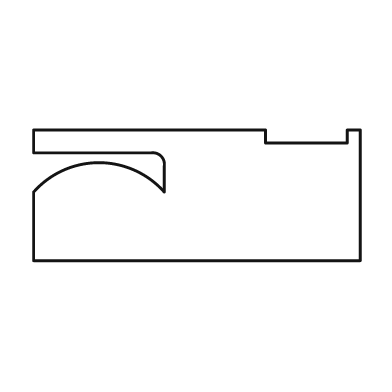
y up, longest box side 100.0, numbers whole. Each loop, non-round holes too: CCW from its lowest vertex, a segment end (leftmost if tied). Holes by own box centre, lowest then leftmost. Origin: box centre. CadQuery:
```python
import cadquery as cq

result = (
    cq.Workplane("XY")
    .moveTo(-50.0, -20.0)
    .lineTo(50.0, -20.0)
    .lineTo(50.0, 20.0)
    .lineTo(46.0, 20.0)
    .lineTo(46.0, 16.0)
    .lineTo(21.0, 16.0)
    .lineTo(21.0, 20.0)
    .lineTo(-50.0, 20.0)
    .lineTo(-50.0, 13.0)
    .lineTo(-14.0, 13.0)
    .threePointArc((-11.0, 12.0), (-10.0, 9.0))
    .lineTo(-10.0, 1.0)
    .threePointArc((-30.0, 10.0), (-50.0, 1.0))
    .close()
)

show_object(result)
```